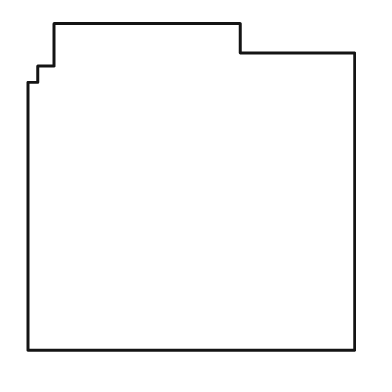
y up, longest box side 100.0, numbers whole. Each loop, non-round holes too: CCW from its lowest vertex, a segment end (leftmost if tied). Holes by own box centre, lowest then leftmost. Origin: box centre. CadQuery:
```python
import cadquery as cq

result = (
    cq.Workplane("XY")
    .moveTo(-50.0, -50.0)
    .lineTo(50.0, -50.0)
    .lineTo(50.0, 41.0)
    .lineTo(15.0, 41.0)
    .lineTo(15.0, 50.0)
    .lineTo(-42.0, 50.0)
    .lineTo(-42.0, 37.0)
    .lineTo(-47.0, 37.0)
    .lineTo(-47.0, 32.0)
    .lineTo(-50.0, 32.0)
    .close()
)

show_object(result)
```